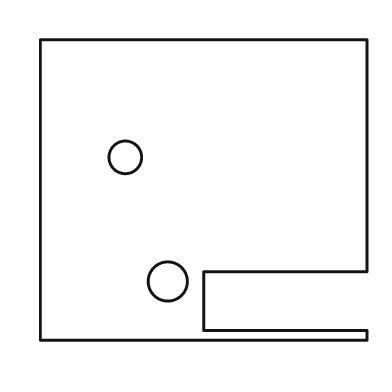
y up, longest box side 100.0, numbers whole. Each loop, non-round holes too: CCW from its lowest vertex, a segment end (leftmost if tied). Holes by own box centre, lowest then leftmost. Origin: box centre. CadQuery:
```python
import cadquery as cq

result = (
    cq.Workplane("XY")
    .moveTo(-50.0, -46.0)
    .lineTo(50.0, -46.0)
    .lineTo(50.0, -43.0)
    .lineTo(0.0, -43.0)
    .lineTo(0.0, -25.0)
    .lineTo(50.0, -25.0)
    .lineTo(50.0, 46.0)
    .lineTo(-50.0, 46.0)
    .close()
    .moveTo(-11.0, -28.0)
    .circle(6.0)
    .moveTo(-24.0, 10.0)
    .circle(5.0)
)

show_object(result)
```